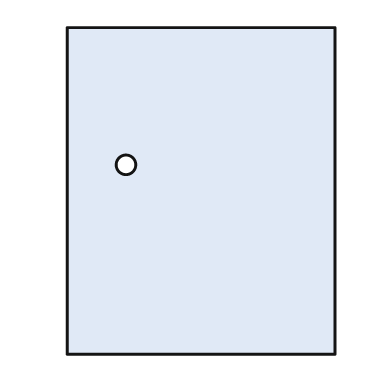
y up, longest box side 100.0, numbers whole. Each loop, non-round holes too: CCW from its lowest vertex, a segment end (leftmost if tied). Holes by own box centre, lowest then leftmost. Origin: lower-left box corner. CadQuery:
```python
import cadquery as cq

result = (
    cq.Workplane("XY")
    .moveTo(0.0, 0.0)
    .lineTo(82.0, 0.0)
    .lineTo(82.0, 100.0)
    .lineTo(0.0, 100.0)
    .close()
    .moveTo(18.0, 58.0)
    .circle(3.0)
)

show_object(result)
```